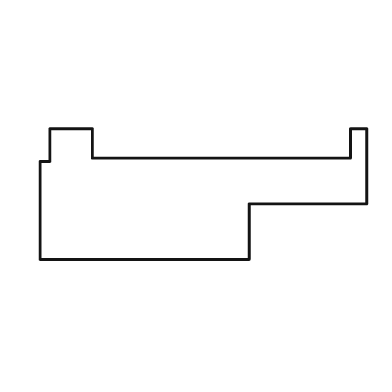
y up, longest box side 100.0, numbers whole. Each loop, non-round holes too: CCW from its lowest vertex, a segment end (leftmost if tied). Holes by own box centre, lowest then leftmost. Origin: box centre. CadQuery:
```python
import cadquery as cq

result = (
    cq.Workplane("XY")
    .moveTo(-50.0, -20.0)
    .lineTo(14.0, -20.0)
    .lineTo(14.0, -3.0)
    .lineTo(50.0, -3.0)
    .lineTo(50.0, 20.0)
    .lineTo(45.0, 20.0)
    .lineTo(45.0, 11.0)
    .lineTo(-34.0, 11.0)
    .lineTo(-34.0, 20.0)
    .lineTo(-47.0, 20.0)
    .lineTo(-47.0, 10.0)
    .lineTo(-50.0, 10.0)
    .close()
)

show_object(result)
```